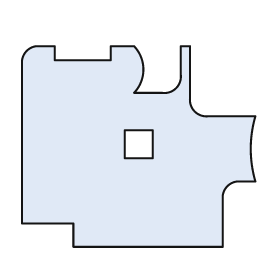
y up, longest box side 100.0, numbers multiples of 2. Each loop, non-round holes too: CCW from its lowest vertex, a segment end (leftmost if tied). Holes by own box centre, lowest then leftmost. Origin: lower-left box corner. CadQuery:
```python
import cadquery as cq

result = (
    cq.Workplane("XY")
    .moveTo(22.0, 0.0)
    .lineTo(86.0, 0.0)
    .lineTo(86.0, 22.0)
    .threePointArc((88.0, 26.0), (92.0, 28.0))
    .lineTo(100.0, 28.0)
    .threePointArc((98.0, 42.0), (100.0, 56.0))
    .lineTo(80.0, 56.0)
    .threePointArc((74.0, 58.0), (72.0, 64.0))
    .lineTo(72.0, 86.0)
    .lineTo(68.0, 86.0)
    .lineTo(68.0, 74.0)
    .threePointArc((66.0, 68.0), (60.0, 66.0))
    .lineTo(48.0, 66.0)
    .threePointArc((52.0, 76.0), (48.0, 86.0))
    .lineTo(38.0, 86.0)
    .lineTo(38.0, 80.0)
    .lineTo(14.0, 80.0)
    .lineTo(14.0, 86.0)
    .lineTo(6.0, 86.0)
    .threePointArc((2.0, 84.0), (0.0, 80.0))
    .lineTo(0.0, 10.0)
    .lineTo(22.0, 10.0)
    .close()
    .moveTo(44.0, 38.0)
    .lineTo(56.0, 38.0)
    .lineTo(56.0, 50.0)
    .lineTo(44.0, 50.0)
    .close()
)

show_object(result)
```